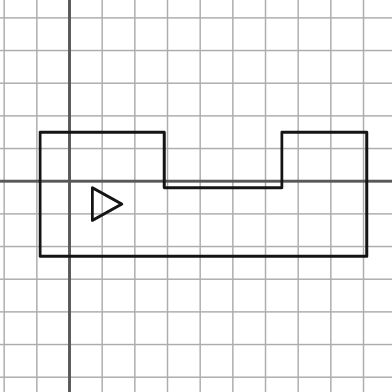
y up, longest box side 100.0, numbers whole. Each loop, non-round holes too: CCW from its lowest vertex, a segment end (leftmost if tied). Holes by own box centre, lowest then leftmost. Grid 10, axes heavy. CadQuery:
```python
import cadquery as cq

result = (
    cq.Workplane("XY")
    .moveTo(-9.0, -23.0)
    .lineTo(91.0, -23.0)
    .lineTo(91.0, 15.0)
    .lineTo(65.0, 15.0)
    .lineTo(65.0, -2.0)
    .lineTo(29.0, -2.0)
    .lineTo(29.0, 15.0)
    .lineTo(-9.0, 15.0)
    .close()
    .moveTo(7.0, -12.0)
    .lineTo(16.0, -7.0)
    .lineTo(7.0, -2.0)
    .close()
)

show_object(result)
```